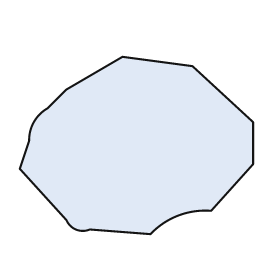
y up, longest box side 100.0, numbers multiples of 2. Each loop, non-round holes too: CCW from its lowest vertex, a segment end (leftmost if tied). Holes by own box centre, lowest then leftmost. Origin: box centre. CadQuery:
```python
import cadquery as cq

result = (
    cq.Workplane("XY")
    .moveTo(6.0, -38.0)
    .threePointArc((18.0, -30.0), (32.0, -28.0))
    .lineTo(50.0, -8.0)
    .lineTo(50.0, 10.0)
    .lineTo(24.0, 34.0)
    .lineTo(-6.0, 38.0)
    .lineTo(-30.0, 24.0)
    .lineTo(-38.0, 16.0)
    .threePointArc((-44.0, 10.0), (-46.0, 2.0))
    .lineTo(-50.0, -10.0)
    .lineTo(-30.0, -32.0)
    .threePointArc((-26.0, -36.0), (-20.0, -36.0))
    .close()
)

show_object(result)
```